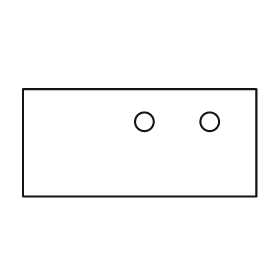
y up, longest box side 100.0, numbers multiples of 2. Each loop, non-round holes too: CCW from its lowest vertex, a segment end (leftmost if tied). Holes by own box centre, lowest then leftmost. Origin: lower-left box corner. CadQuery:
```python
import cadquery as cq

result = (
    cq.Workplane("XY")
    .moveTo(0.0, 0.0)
    .lineTo(100.0, 0.0)
    .lineTo(100.0, 46.0)
    .lineTo(0.0, 46.0)
    .close()
    .moveTo(52.0, 32.0)
    .circle(4.0)
    .moveTo(80.0, 32.0)
    .circle(4.0)
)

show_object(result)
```